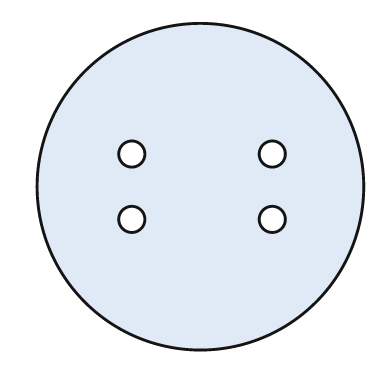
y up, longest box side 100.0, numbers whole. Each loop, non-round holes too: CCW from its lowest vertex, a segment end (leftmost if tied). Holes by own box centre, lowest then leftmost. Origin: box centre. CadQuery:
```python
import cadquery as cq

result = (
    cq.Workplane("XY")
    .moveTo(0.0, 0.0)
    .circle(50.0)
    .moveTo(-21.0, -10.0)
    .circle(4.0)
    .moveTo(22.0, -10.0)
    .circle(4.0)
    .moveTo(-21.0, 10.0)
    .circle(4.0)
    .moveTo(22.0, 10.0)
    .circle(4.0)
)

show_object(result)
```